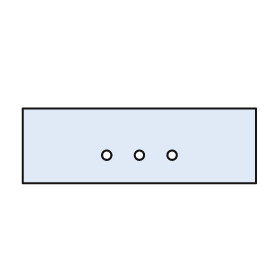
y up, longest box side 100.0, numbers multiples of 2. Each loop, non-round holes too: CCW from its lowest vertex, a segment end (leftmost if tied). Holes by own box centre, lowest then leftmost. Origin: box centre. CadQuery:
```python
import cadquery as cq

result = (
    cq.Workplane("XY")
    .moveTo(-50.0, -16.0)
    .lineTo(50.0, -16.0)
    .lineTo(50.0, 16.0)
    .lineTo(-50.0, 16.0)
    .close()
    .moveTo(-14.0, -4.0)
    .circle(2.0)
    .moveTo(0.0, -4.0)
    .circle(2.0)
    .moveTo(14.0, -4.0)
    .circle(2.0)
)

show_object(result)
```